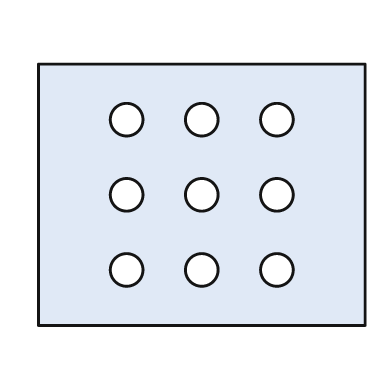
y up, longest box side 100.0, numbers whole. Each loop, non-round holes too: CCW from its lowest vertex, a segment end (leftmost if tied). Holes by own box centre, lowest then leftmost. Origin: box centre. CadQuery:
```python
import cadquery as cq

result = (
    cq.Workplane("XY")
    .moveTo(-50.0, -40.0)
    .lineTo(50.0, -40.0)
    .lineTo(50.0, 40.0)
    .lineTo(-50.0, 40.0)
    .close()
    .moveTo(-23.0, -23.0)
    .circle(5.0)
    .moveTo(0.0, -23.0)
    .circle(5.0)
    .moveTo(23.0, -23.0)
    .circle(5.0)
    .moveTo(-23.0, 0.0)
    .circle(5.0)
    .moveTo(0.0, 0.0)
    .circle(5.0)
    .moveTo(23.0, 0.0)
    .circle(5.0)
    .moveTo(-23.0, 23.0)
    .circle(5.0)
    .moveTo(0.0, 23.0)
    .circle(5.0)
    .moveTo(23.0, 23.0)
    .circle(5.0)
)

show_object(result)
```